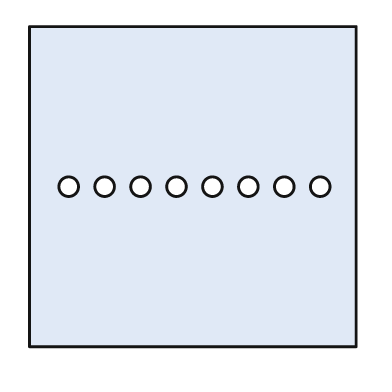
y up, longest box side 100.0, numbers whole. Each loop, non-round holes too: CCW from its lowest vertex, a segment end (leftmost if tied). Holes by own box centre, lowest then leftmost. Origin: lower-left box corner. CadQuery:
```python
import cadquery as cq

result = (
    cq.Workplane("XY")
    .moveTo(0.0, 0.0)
    .lineTo(100.0, 0.0)
    .lineTo(100.0, 98.0)
    .lineTo(0.0, 98.0)
    .close()
    .moveTo(12.0, 49.0)
    .circle(3.0)
    .moveTo(23.0, 49.0)
    .circle(3.0)
    .moveTo(34.0, 49.0)
    .circle(3.0)
    .moveTo(45.0, 49.0)
    .circle(3.0)
    .moveTo(56.0, 49.0)
    .circle(3.0)
    .moveTo(67.0, 49.0)
    .circle(3.0)
    .moveTo(78.0, 49.0)
    .circle(3.0)
    .moveTo(89.0, 49.0)
    .circle(3.0)
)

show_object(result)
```